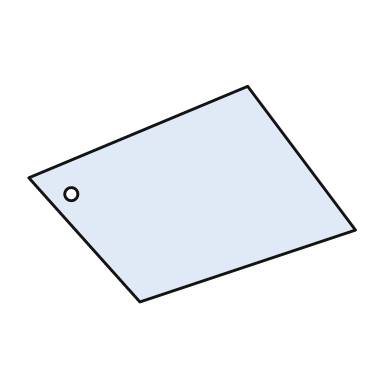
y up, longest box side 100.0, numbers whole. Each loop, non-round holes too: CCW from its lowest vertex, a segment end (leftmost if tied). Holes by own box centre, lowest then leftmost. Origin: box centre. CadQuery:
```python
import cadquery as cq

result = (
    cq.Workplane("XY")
    .moveTo(-16.0, -33.0)
    .lineTo(50.0, -11.0)
    .lineTo(17.0, 33.0)
    .lineTo(-50.0, 5.0)
    .close()
    .moveTo(-37.0, 0.0)
    .circle(2.0)
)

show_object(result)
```